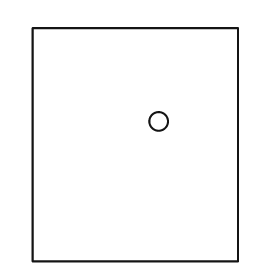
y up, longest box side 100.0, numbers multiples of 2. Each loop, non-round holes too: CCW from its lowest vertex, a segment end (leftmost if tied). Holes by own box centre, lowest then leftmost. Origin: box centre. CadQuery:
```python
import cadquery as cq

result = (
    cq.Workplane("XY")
    .moveTo(-44.0, -50.0)
    .lineTo(44.0, -50.0)
    .lineTo(44.0, 50.0)
    .lineTo(-44.0, 50.0)
    .close()
    .moveTo(10.0, 10.0)
    .circle(4.0)
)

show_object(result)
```